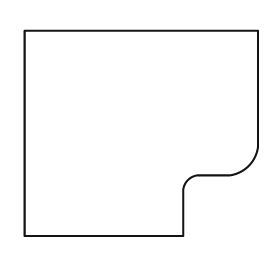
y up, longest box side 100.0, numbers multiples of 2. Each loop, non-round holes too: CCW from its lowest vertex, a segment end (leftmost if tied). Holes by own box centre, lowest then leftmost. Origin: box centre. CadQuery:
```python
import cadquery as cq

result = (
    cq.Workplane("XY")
    .moveTo(-50.0, -44.0)
    .lineTo(18.0, -44.0)
    .lineTo(18.0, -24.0)
    .threePointArc((20.0, -20.0), (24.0, -18.0))
    .lineTo(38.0, -18.0)
    .threePointArc((46.0, -14.0), (50.0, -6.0))
    .lineTo(50.0, 44.0)
    .lineTo(-50.0, 44.0)
    .close()
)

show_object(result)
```